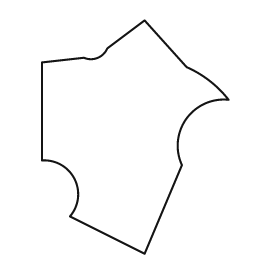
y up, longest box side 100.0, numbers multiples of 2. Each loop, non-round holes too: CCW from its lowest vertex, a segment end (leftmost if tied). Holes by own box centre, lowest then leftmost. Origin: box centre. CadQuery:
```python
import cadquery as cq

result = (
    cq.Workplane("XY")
    .moveTo(4.0, -50.0)
    .lineTo(20.0, -12.0)
    .threePointArc((22.0, 8.0), (40.0, 16.0))
    .threePointArc((32.0, 24.0), (22.0, 30.0))
    .lineTo(4.0, 50.0)
    .lineTo(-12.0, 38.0)
    .threePointArc((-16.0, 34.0), (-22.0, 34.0))
    .lineTo(-40.0, 32.0)
    .lineTo(-40.0, -10.0)
    .threePointArc((-26.0, -18.0), (-28.0, -34.0))
    .close()
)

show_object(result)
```